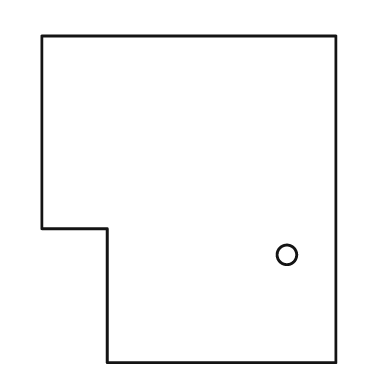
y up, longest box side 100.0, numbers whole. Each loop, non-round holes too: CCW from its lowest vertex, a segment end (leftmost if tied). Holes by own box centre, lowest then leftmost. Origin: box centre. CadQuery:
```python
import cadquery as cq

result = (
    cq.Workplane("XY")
    .moveTo(-25.0, -50.0)
    .lineTo(45.0, -50.0)
    .lineTo(45.0, 50.0)
    .lineTo(-45.0, 50.0)
    .lineTo(-45.0, -9.0)
    .lineTo(-25.0, -9.0)
    .close()
    .moveTo(30.0, -17.0)
    .circle(3.0)
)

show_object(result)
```